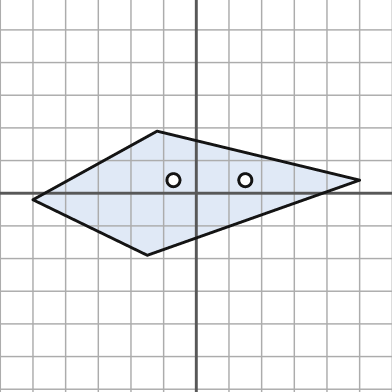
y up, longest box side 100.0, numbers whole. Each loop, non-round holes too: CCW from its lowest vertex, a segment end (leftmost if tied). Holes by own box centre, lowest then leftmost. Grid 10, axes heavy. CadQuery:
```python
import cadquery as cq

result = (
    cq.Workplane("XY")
    .moveTo(-15.0, -19.0)
    .lineTo(50.0, 4.0)
    .lineTo(-12.0, 19.0)
    .lineTo(-50.0, -2.0)
    .close()
    .moveTo(-7.0, 4.0)
    .circle(2.0)
    .moveTo(15.0, 4.0)
    .circle(2.0)
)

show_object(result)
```